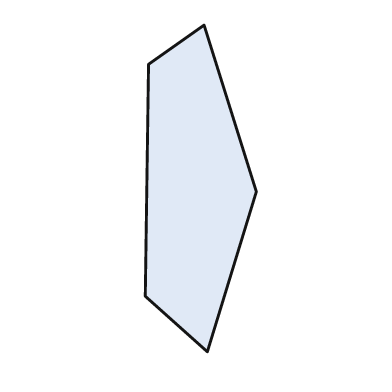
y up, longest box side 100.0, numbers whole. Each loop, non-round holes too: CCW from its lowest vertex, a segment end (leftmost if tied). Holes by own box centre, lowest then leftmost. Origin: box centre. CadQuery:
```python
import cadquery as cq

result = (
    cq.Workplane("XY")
    .moveTo(2.0, -50.0)
    .lineTo(17.0, -1.0)
    .lineTo(1.0, 50.0)
    .lineTo(-16.0, 38.0)
    .lineTo(-17.0, -33.0)
    .close()
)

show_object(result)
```